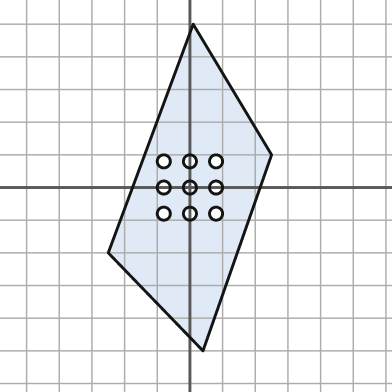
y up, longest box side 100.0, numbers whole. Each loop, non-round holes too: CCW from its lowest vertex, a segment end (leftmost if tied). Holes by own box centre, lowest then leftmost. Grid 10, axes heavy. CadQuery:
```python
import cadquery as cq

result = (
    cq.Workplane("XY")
    .moveTo(4.0, -50.0)
    .lineTo(25.0, 10.0)
    .lineTo(1.0, 50.0)
    .lineTo(-25.0, -20.0)
    .close()
    .moveTo(-8.0, -8.0)
    .circle(2.0)
    .moveTo(0.0, -8.0)
    .circle(2.0)
    .moveTo(8.0, -8.0)
    .circle(2.0)
    .moveTo(-8.0, 0.0)
    .circle(2.0)
    .moveTo(0.0, 0.0)
    .circle(2.0)
    .moveTo(8.0, 0.0)
    .circle(2.0)
    .moveTo(-8.0, 8.0)
    .circle(2.0)
    .moveTo(0.0, 8.0)
    .circle(2.0)
    .moveTo(8.0, 8.0)
    .circle(2.0)
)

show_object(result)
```